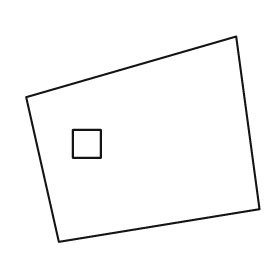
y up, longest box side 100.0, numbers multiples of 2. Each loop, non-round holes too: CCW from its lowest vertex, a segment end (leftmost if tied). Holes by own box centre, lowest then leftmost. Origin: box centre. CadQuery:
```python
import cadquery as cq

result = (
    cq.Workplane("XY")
    .moveTo(-36.0, -44.0)
    .lineTo(50.0, -30.0)
    .lineTo(40.0, 44.0)
    .lineTo(-50.0, 18.0)
    .close()
    .moveTo(-30.0, -8.0)
    .lineTo(-18.0, -8.0)
    .lineTo(-18.0, 4.0)
    .lineTo(-30.0, 4.0)
    .close()
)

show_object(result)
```